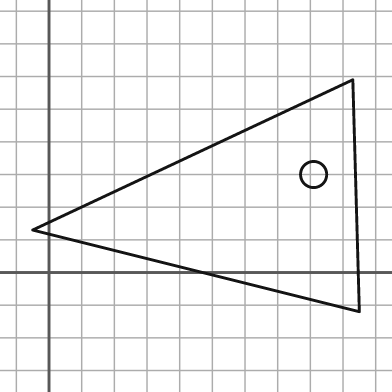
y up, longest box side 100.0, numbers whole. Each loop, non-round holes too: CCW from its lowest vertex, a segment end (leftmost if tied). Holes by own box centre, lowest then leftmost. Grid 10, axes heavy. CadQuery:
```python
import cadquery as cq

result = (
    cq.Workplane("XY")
    .moveTo(95.0, -12.0)
    .lineTo(93.0, 59.0)
    .lineTo(-5.0, 13.0)
    .close()
    .moveTo(81.0, 30.0)
    .circle(4.0)
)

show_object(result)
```